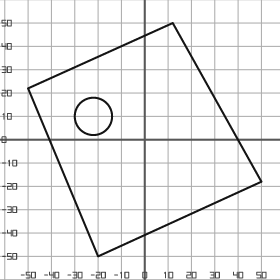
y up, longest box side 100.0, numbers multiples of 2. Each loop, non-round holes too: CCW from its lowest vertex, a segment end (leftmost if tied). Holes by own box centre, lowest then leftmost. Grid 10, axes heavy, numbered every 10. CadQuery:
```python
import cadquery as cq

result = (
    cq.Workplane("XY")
    .moveTo(-20.0, -50.0)
    .lineTo(50.0, -18.0)
    .lineTo(12.0, 50.0)
    .lineTo(-50.0, 22.0)
    .close()
    .moveTo(-22.0, 10.0)
    .circle(8.0)
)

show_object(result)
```